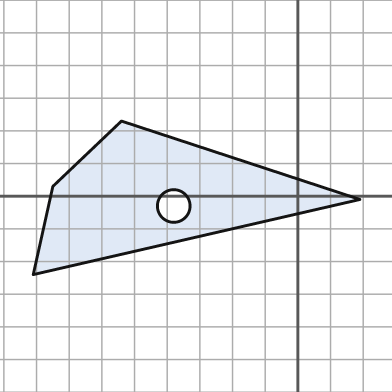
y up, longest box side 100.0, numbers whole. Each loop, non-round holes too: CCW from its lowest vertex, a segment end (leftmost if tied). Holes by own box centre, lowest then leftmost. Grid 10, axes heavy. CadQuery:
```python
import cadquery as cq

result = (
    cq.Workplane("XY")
    .moveTo(-81.0, -24.0)
    .lineTo(19.0, -1.0)
    .lineTo(-54.0, 23.0)
    .lineTo(-75.0, 3.0)
    .close()
    .moveTo(-38.0, -3.0)
    .circle(5.0)
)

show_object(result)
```